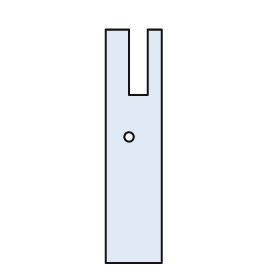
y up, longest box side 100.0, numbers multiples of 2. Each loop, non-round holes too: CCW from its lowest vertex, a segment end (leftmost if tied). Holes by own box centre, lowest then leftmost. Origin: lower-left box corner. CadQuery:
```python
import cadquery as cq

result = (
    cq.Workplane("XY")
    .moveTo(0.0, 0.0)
    .lineTo(24.0, 0.0)
    .lineTo(24.0, 100.0)
    .lineTo(18.0, 100.0)
    .lineTo(18.0, 72.0)
    .lineTo(10.0, 72.0)
    .lineTo(10.0, 100.0)
    .lineTo(0.0, 100.0)
    .close()
    .moveTo(10.0, 54.0)
    .circle(2.0)
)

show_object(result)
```